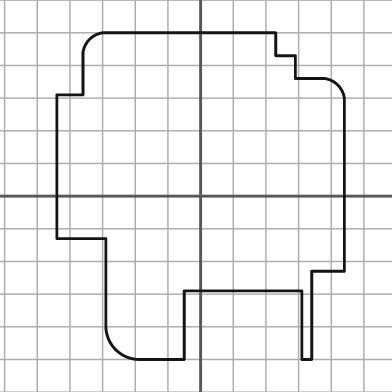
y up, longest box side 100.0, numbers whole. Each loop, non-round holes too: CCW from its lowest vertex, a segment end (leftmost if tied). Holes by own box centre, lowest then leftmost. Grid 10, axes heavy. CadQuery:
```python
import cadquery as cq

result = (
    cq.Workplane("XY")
    .moveTo(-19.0, -50.0)
    .lineTo(-5.0, -50.0)
    .lineTo(-5.0, -29.0)
    .lineTo(31.0, -29.0)
    .lineTo(31.0, -50.0)
    .lineTo(34.0, -50.0)
    .lineTo(34.0, -23.0)
    .lineTo(44.0, -23.0)
    .lineTo(44.0, 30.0)
    .threePointArc((42.0, 34.0), (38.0, 36.0))
    .lineTo(29.0, 36.0)
    .lineTo(29.0, 43.0)
    .lineTo(23.0, 43.0)
    .lineTo(23.0, 50.0)
    .lineTo(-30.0, 50.0)
    .threePointArc((-34.0, 48.0), (-36.0, 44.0))
    .lineTo(-36.0, 31.0)
    .lineTo(-44.0, 31.0)
    .lineTo(-44.0, -13.0)
    .lineTo(-29.0, -13.0)
    .lineTo(-29.0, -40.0)
    .threePointArc((-26.0, -47.0), (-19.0, -50.0))
    .close()
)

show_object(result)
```